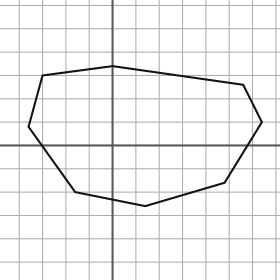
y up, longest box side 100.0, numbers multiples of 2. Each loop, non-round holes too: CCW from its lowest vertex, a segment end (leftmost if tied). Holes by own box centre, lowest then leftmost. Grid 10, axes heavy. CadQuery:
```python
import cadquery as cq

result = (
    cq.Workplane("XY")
    .moveTo(14.0, -26.0)
    .lineTo(48.0, -16.0)
    .lineTo(64.0, 10.0)
    .lineTo(56.0, 26.0)
    .lineTo(0.0, 34.0)
    .lineTo(-30.0, 30.0)
    .lineTo(-36.0, 8.0)
    .lineTo(-16.0, -20.0)
    .close()
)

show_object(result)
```